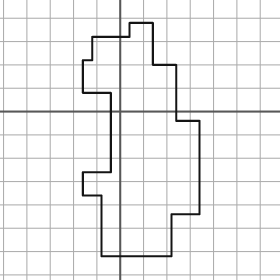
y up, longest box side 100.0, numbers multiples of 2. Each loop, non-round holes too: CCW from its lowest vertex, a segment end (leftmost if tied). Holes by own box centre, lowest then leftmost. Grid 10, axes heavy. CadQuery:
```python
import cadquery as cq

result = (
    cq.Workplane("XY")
    .moveTo(-8.0, -62.0)
    .lineTo(22.0, -62.0)
    .lineTo(22.0, -44.0)
    .lineTo(34.0, -44.0)
    .lineTo(34.0, -4.0)
    .lineTo(24.0, -4.0)
    .lineTo(24.0, 20.0)
    .lineTo(14.0, 20.0)
    .lineTo(14.0, 38.0)
    .lineTo(4.0, 38.0)
    .lineTo(4.0, 32.0)
    .lineTo(-12.0, 32.0)
    .lineTo(-12.0, 22.0)
    .lineTo(-16.0, 22.0)
    .lineTo(-16.0, 8.0)
    .lineTo(-4.0, 8.0)
    .lineTo(-4.0, -26.0)
    .lineTo(-16.0, -26.0)
    .lineTo(-16.0, -36.0)
    .lineTo(-8.0, -36.0)
    .close()
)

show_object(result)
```